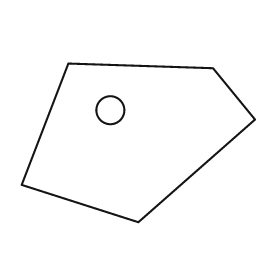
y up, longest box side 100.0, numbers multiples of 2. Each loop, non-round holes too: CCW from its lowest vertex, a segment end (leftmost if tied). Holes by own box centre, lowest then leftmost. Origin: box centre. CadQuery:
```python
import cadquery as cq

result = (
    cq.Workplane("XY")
    .moveTo(0.0, -34.0)
    .lineTo(50.0, 10.0)
    .lineTo(32.0, 32.0)
    .lineTo(-30.0, 34.0)
    .lineTo(-50.0, -18.0)
    .close()
    .moveTo(-12.0, 14.0)
    .circle(6.0)
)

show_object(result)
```